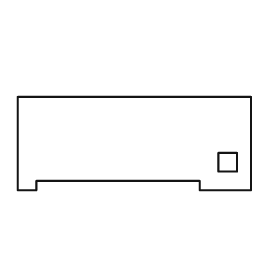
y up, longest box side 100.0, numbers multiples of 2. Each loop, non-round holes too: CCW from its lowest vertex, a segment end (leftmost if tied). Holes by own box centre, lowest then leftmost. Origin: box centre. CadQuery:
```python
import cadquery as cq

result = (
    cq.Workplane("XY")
    .moveTo(-50.0, -20.0)
    .lineTo(-42.0, -20.0)
    .lineTo(-42.0, -16.0)
    .lineTo(28.0, -16.0)
    .lineTo(28.0, -20.0)
    .lineTo(50.0, -20.0)
    .lineTo(50.0, 20.0)
    .lineTo(-50.0, 20.0)
    .close()
    .moveTo(36.0, -12.0)
    .lineTo(44.0, -12.0)
    .lineTo(44.0, -4.0)
    .lineTo(36.0, -4.0)
    .close()
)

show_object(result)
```